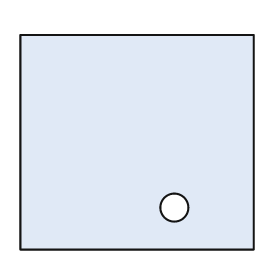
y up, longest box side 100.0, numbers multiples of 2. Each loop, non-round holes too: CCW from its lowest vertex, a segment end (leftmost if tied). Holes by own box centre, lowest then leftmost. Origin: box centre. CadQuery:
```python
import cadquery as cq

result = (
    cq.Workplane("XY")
    .moveTo(-50.0, -46.0)
    .lineTo(50.0, -46.0)
    .lineTo(50.0, 46.0)
    .lineTo(-50.0, 46.0)
    .close()
    .moveTo(16.0, -28.0)
    .circle(6.0)
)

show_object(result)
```